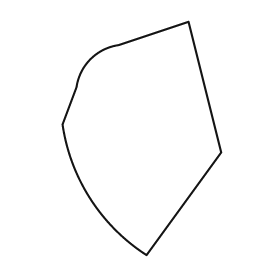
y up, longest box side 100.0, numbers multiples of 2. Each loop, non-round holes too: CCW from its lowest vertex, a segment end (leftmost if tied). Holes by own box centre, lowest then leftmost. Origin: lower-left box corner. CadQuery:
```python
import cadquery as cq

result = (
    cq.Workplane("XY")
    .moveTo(36.0, 0.0)
    .lineTo(68.0, 44.0)
    .lineTo(54.0, 100.0)
    .lineTo(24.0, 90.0)
    .threePointArc((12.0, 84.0), (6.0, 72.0))
    .lineTo(0.0, 56.0)
    .threePointArc((12.0, 24.0), (36.0, 0.0))
    .close()
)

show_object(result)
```